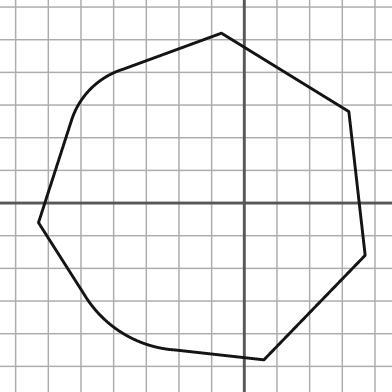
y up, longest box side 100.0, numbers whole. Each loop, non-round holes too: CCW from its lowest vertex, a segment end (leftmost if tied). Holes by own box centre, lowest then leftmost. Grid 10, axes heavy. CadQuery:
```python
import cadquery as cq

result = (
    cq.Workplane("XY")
    .moveTo(6.0, -48.0)
    .lineTo(37.0, -16.0)
    .lineTo(32.0, 28.0)
    .lineTo(-7.0, 52.0)
    .lineTo(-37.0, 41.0)
    .threePointArc((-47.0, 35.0), (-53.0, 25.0))
    .lineTo(-63.0, -6.0)
    .lineTo(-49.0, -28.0)
    .threePointArc((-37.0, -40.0), (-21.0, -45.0))
    .close()
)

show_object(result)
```